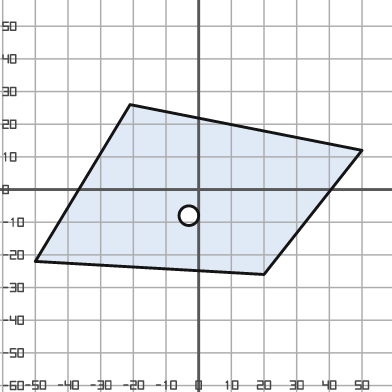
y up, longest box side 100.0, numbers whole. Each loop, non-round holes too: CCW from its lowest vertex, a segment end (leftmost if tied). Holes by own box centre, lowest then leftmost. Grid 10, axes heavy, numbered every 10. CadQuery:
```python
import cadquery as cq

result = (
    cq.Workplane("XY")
    .moveTo(20.0, -26.0)
    .lineTo(50.0, 12.0)
    .lineTo(-21.0, 26.0)
    .lineTo(-50.0, -22.0)
    .close()
    .moveTo(-3.0, -8.0)
    .circle(3.0)
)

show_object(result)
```